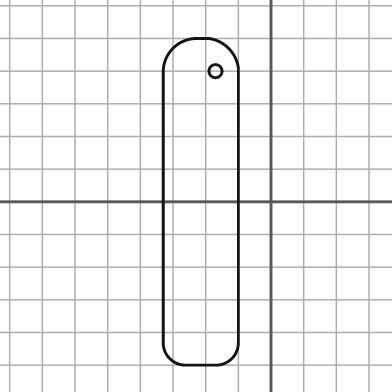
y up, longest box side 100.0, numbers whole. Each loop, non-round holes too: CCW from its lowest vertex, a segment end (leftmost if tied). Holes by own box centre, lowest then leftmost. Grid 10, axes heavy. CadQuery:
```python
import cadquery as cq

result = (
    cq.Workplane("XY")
    .moveTo(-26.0, -50.0)
    .lineTo(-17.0, -50.0)
    .threePointArc((-12.0, -48.0), (-10.0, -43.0))
    .lineTo(-10.0, 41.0)
    .threePointArc((-13.0, 47.0), (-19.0, 50.0))
    .lineTo(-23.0, 50.0)
    .threePointArc((-30.0, 47.0), (-33.0, 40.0))
    .lineTo(-33.0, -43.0)
    .threePointArc((-31.0, -48.0), (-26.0, -50.0))
    .close()
    .moveTo(-17.0, 40.0)
    .circle(2.0)
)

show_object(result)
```